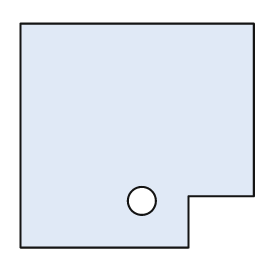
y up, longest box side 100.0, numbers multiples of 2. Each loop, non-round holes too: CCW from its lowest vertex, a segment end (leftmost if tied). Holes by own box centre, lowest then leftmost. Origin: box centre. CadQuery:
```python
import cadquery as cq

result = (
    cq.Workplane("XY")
    .moveTo(-50.0, -48.0)
    .lineTo(22.0, -48.0)
    .lineTo(22.0, -26.0)
    .lineTo(50.0, -26.0)
    .lineTo(50.0, 48.0)
    .lineTo(-50.0, 48.0)
    .close()
    .moveTo(2.0, -28.0)
    .circle(6.0)
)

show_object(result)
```